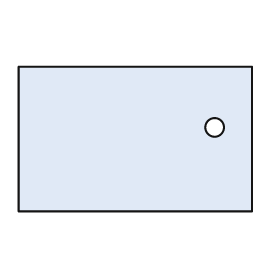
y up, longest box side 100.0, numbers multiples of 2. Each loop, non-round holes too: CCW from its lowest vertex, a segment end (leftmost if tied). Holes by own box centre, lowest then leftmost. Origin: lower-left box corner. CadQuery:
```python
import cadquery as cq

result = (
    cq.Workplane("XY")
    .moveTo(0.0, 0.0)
    .lineTo(100.0, 0.0)
    .lineTo(100.0, 62.0)
    .lineTo(0.0, 62.0)
    .close()
    .moveTo(84.0, 36.0)
    .circle(4.0)
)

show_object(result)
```